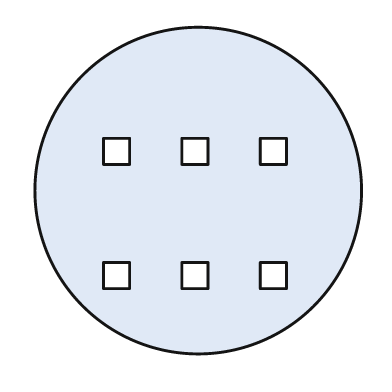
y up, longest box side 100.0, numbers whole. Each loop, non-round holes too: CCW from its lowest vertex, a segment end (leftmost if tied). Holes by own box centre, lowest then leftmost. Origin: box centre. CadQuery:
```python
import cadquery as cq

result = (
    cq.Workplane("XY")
    .moveTo(0.0, 0.0)
    .circle(50.0)
    .moveTo(-29.0, -30.0)
    .lineTo(-21.0, -30.0)
    .lineTo(-21.0, -22.0)
    .lineTo(-29.0, -22.0)
    .close()
    .moveTo(-5.0, -30.0)
    .lineTo(3.0, -30.0)
    .lineTo(3.0, -22.0)
    .lineTo(-5.0, -22.0)
    .close()
    .moveTo(19.0, -30.0)
    .lineTo(27.0, -30.0)
    .lineTo(27.0, -22.0)
    .lineTo(19.0, -22.0)
    .close()
    .moveTo(-29.0, 8.0)
    .lineTo(-21.0, 8.0)
    .lineTo(-21.0, 16.0)
    .lineTo(-29.0, 16.0)
    .close()
    .moveTo(-5.0, 8.0)
    .lineTo(3.0, 8.0)
    .lineTo(3.0, 16.0)
    .lineTo(-5.0, 16.0)
    .close()
    .moveTo(19.0, 8.0)
    .lineTo(27.0, 8.0)
    .lineTo(27.0, 16.0)
    .lineTo(19.0, 16.0)
    .close()
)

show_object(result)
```